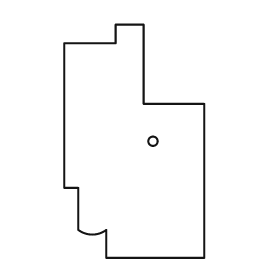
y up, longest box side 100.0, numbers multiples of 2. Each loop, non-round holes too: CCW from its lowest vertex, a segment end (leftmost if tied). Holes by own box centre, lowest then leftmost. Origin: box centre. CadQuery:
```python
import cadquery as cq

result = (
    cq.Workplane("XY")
    .moveTo(-12.0, -50.0)
    .lineTo(30.0, -50.0)
    .lineTo(30.0, 16.0)
    .lineTo(4.0, 16.0)
    .lineTo(4.0, 50.0)
    .lineTo(-8.0, 50.0)
    .lineTo(-8.0, 42.0)
    .lineTo(-30.0, 42.0)
    .lineTo(-30.0, -20.0)
    .lineTo(-24.0, -20.0)
    .lineTo(-24.0, -38.0)
    .threePointArc((-18.0, -40.0), (-12.0, -38.0))
    .close()
    .moveTo(8.0, 0.0)
    .circle(2.0)
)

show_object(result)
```